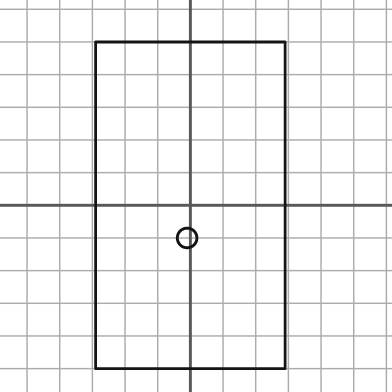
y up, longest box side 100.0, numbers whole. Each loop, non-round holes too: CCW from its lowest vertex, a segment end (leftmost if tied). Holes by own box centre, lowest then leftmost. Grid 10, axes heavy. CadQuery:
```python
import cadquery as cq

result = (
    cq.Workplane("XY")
    .moveTo(-29.0, -50.0)
    .lineTo(29.0, -50.0)
    .lineTo(29.0, 50.0)
    .lineTo(-29.0, 50.0)
    .close()
    .moveTo(-1.0, -10.0)
    .circle(3.0)
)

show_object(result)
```